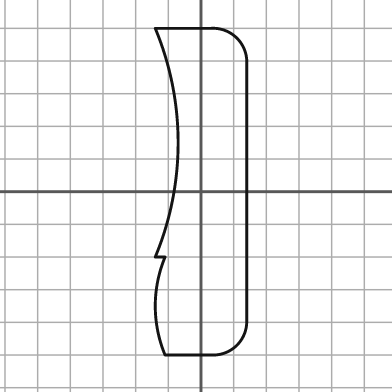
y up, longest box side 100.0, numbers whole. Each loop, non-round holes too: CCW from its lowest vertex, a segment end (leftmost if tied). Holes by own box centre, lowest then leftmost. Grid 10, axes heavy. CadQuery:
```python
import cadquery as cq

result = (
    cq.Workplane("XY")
    .moveTo(-11.0, -50.0)
    .lineTo(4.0, -50.0)
    .threePointArc((11.0, -47.0), (14.0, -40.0))
    .lineTo(14.0, 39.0)
    .threePointArc((11.0, 47.0), (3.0, 50.0))
    .lineTo(-14.0, 50.0)
    .threePointArc((-7.0, 15.0), (-14.0, -20.0))
    .lineTo(-11.0, -20.0)
    .threePointArc((-14.0, -35.0), (-11.0, -50.0))
    .close()
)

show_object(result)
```